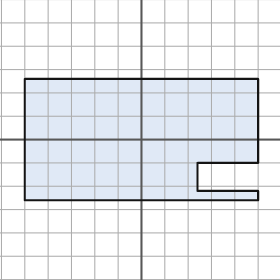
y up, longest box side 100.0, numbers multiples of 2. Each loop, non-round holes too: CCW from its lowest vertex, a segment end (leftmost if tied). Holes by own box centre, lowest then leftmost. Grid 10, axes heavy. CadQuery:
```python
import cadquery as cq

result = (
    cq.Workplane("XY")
    .moveTo(-50.0, -26.0)
    .lineTo(50.0, -26.0)
    .lineTo(50.0, -22.0)
    .lineTo(24.0, -22.0)
    .lineTo(24.0, -10.0)
    .lineTo(50.0, -10.0)
    .lineTo(50.0, 26.0)
    .lineTo(-50.0, 26.0)
    .close()
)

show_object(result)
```